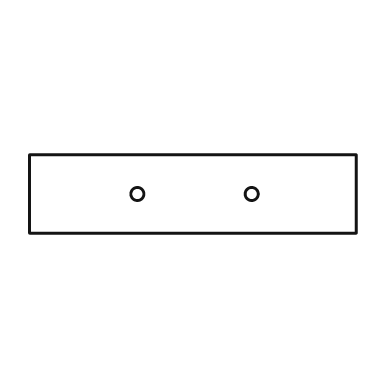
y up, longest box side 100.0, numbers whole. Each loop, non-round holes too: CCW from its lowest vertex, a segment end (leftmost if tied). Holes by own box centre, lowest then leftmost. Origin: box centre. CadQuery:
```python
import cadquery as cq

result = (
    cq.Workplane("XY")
    .moveTo(-50.0, -12.0)
    .lineTo(50.0, -12.0)
    .lineTo(50.0, 12.0)
    .lineTo(-50.0, 12.0)
    .close()
    .moveTo(-17.0, 0.0)
    .circle(2.0)
    .moveTo(18.0, 0.0)
    .circle(2.0)
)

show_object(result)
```